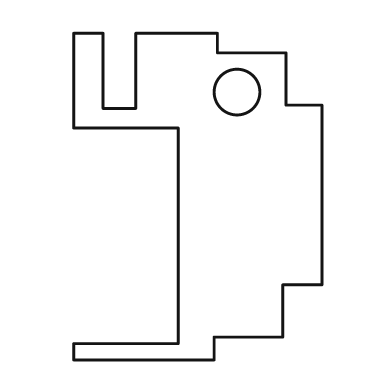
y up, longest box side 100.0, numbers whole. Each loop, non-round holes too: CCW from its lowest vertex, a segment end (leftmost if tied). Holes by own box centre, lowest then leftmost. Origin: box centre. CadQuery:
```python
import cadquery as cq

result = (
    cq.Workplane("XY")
    .moveTo(-38.0, -50.0)
    .lineTo(5.0, -50.0)
    .lineTo(5.0, -43.0)
    .lineTo(26.0, -43.0)
    .lineTo(26.0, -27.0)
    .lineTo(38.0, -27.0)
    .lineTo(38.0, 28.0)
    .lineTo(27.0, 28.0)
    .lineTo(27.0, 44.0)
    .lineTo(6.0, 44.0)
    .lineTo(6.0, 50.0)
    .lineTo(-19.0, 50.0)
    .lineTo(-19.0, 27.0)
    .lineTo(-29.0, 27.0)
    .lineTo(-29.0, 50.0)
    .lineTo(-38.0, 50.0)
    .lineTo(-38.0, 21.0)
    .lineTo(-6.0, 21.0)
    .lineTo(-6.0, -45.0)
    .lineTo(-38.0, -45.0)
    .close()
    .moveTo(12.0, 32.0)
    .circle(7.0)
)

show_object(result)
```